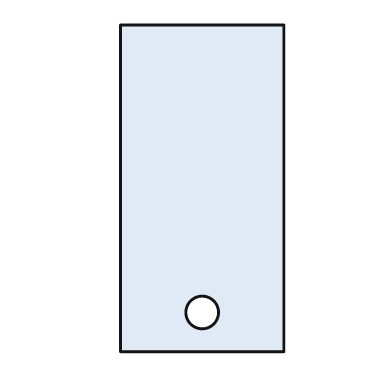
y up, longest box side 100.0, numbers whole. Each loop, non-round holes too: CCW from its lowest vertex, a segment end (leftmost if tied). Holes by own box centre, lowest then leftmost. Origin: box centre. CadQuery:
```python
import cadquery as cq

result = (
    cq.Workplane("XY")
    .moveTo(-25.0, -50.0)
    .lineTo(25.0, -50.0)
    .lineTo(25.0, 50.0)
    .lineTo(-25.0, 50.0)
    .close()
    .moveTo(0.0, -38.0)
    .circle(5.0)
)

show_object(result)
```